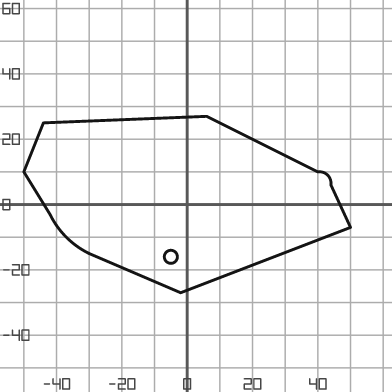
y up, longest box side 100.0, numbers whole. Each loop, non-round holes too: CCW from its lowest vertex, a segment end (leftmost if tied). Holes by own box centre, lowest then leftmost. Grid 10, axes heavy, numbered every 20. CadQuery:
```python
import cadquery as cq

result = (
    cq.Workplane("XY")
    .moveTo(-2.0, -27.0)
    .lineTo(50.0, -7.0)
    .lineTo(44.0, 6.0)
    .threePointArc((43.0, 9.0), (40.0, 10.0))
    .lineTo(6.0, 27.0)
    .lineTo(-44.0, 25.0)
    .lineTo(-50.0, 10.0)
    .lineTo(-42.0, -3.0)
    .threePointArc((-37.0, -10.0), (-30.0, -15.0))
    .close()
    .moveTo(-5.0, -16.0)
    .circle(2.0)
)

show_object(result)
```